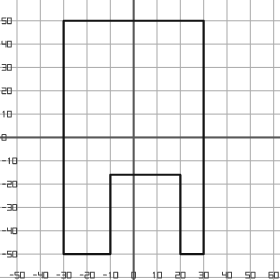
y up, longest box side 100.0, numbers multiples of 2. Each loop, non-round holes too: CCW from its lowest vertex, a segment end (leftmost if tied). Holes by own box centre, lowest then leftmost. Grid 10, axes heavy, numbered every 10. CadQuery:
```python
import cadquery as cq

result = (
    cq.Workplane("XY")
    .moveTo(-30.0, -50.0)
    .lineTo(-10.0, -50.0)
    .lineTo(-10.0, -16.0)
    .lineTo(20.0, -16.0)
    .lineTo(20.0, -50.0)
    .lineTo(30.0, -50.0)
    .lineTo(30.0, 50.0)
    .lineTo(-30.0, 50.0)
    .close()
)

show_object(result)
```